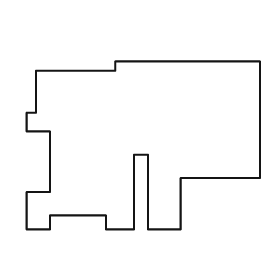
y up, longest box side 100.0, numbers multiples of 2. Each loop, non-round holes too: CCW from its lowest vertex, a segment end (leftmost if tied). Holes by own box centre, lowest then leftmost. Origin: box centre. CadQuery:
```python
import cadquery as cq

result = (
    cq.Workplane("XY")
    .moveTo(-50.0, -36.0)
    .lineTo(-40.0, -36.0)
    .lineTo(-40.0, -30.0)
    .lineTo(-16.0, -30.0)
    .lineTo(-16.0, -36.0)
    .lineTo(-4.0, -36.0)
    .lineTo(-4.0, -4.0)
    .lineTo(2.0, -4.0)
    .lineTo(2.0, -36.0)
    .lineTo(16.0, -36.0)
    .lineTo(16.0, -14.0)
    .lineTo(50.0, -14.0)
    .lineTo(50.0, 36.0)
    .lineTo(-12.0, 36.0)
    .lineTo(-12.0, 32.0)
    .lineTo(-46.0, 32.0)
    .lineTo(-46.0, 14.0)
    .lineTo(-50.0, 14.0)
    .lineTo(-50.0, 6.0)
    .lineTo(-40.0, 6.0)
    .lineTo(-40.0, -20.0)
    .lineTo(-50.0, -20.0)
    .close()
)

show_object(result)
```